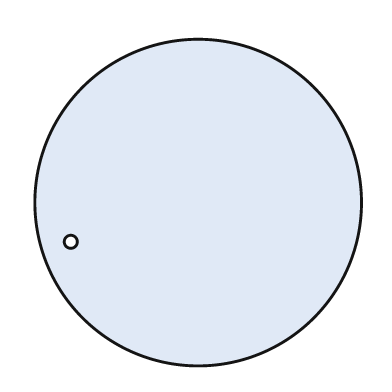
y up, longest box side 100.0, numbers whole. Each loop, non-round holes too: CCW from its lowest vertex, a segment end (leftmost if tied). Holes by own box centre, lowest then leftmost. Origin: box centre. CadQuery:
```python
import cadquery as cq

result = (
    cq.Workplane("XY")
    .moveTo(0.0, 0.0)
    .circle(50.0)
    .moveTo(-39.0, -12.0)
    .circle(2.0)
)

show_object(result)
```